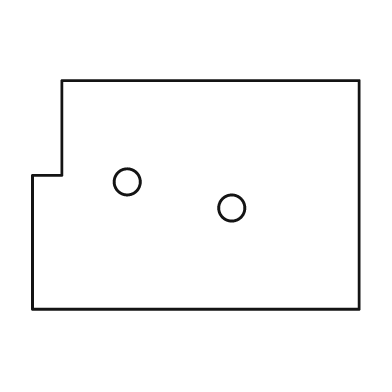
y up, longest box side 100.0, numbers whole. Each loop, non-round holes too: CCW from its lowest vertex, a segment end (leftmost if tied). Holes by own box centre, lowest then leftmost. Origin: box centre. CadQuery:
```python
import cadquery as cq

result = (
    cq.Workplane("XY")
    .moveTo(-50.0, -35.0)
    .lineTo(50.0, -35.0)
    .lineTo(50.0, 35.0)
    .lineTo(-41.0, 35.0)
    .lineTo(-41.0, 6.0)
    .lineTo(-50.0, 6.0)
    .close()
    .moveTo(11.0, -4.0)
    .circle(4.0)
    .moveTo(-21.0, 4.0)
    .circle(4.0)
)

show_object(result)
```